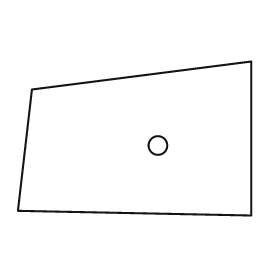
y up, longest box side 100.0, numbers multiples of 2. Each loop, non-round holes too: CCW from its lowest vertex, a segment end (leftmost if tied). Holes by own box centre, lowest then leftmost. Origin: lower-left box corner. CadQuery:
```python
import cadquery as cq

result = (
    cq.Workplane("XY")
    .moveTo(100.0, 0.0)
    .lineTo(100.0, 66.0)
    .lineTo(6.0, 54.0)
    .lineTo(0.0, 2.0)
    .close()
    .moveTo(60.0, 30.0)
    .circle(4.0)
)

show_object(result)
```